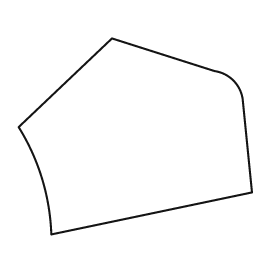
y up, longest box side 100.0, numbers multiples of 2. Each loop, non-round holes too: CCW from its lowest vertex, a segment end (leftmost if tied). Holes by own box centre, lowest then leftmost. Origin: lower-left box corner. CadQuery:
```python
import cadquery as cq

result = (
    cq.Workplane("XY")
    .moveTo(14.0, 0.0)
    .lineTo(100.0, 18.0)
    .lineTo(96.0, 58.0)
    .threePointArc((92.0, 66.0), (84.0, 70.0))
    .lineTo(40.0, 84.0)
    .lineTo(0.0, 46.0)
    .threePointArc((10.0, 24.0), (14.0, 0.0))
    .close()
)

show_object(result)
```